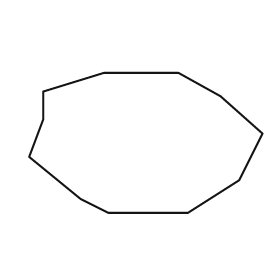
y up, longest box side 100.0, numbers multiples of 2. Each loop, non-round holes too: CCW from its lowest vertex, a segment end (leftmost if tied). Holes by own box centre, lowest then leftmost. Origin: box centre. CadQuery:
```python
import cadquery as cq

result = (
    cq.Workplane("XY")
    .moveTo(-16.0, -30.0)
    .lineTo(18.0, -30.0)
    .lineTo(40.0, -16.0)
    .lineTo(50.0, 4.0)
    .lineTo(32.0, 20.0)
    .lineTo(14.0, 30.0)
    .lineTo(-18.0, 30.0)
    .lineTo(-44.0, 22.0)
    .lineTo(-44.0, 10.0)
    .lineTo(-50.0, -6.0)
    .lineTo(-28.0, -24.0)
    .close()
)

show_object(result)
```